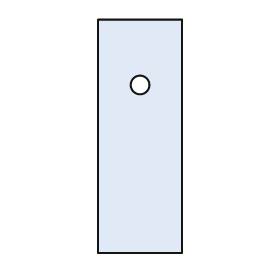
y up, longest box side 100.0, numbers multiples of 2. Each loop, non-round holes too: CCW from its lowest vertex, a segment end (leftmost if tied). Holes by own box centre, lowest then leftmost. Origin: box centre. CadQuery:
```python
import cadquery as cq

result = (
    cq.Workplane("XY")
    .moveTo(-18.0, -50.0)
    .lineTo(18.0, -50.0)
    .lineTo(18.0, 50.0)
    .lineTo(-18.0, 50.0)
    .close()
    .moveTo(0.0, 22.0)
    .circle(4.0)
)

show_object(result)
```